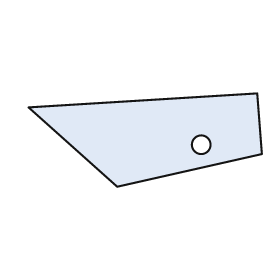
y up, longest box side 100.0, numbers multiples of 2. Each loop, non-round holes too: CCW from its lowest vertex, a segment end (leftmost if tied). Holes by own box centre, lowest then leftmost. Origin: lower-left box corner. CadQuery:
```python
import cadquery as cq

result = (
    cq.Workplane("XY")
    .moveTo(38.0, 0.0)
    .lineTo(100.0, 14.0)
    .lineTo(98.0, 40.0)
    .lineTo(0.0, 34.0)
    .close()
    .moveTo(74.0, 18.0)
    .circle(4.0)
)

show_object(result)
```